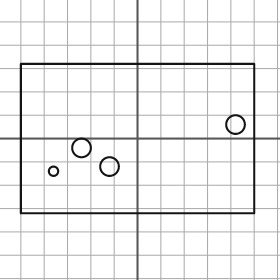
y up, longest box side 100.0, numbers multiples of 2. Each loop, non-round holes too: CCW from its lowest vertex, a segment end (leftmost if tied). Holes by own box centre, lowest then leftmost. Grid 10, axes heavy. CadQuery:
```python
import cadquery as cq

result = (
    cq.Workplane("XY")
    .moveTo(-50.0, -32.0)
    .lineTo(50.0, -32.0)
    .lineTo(50.0, 32.0)
    .lineTo(-50.0, 32.0)
    .close()
    .moveTo(-36.0, -14.0)
    .circle(2.0)
    .moveTo(-12.0, -12.0)
    .circle(4.0)
    .moveTo(-24.0, -4.0)
    .circle(4.0)
    .moveTo(42.0, 6.0)
    .circle(4.0)
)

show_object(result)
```